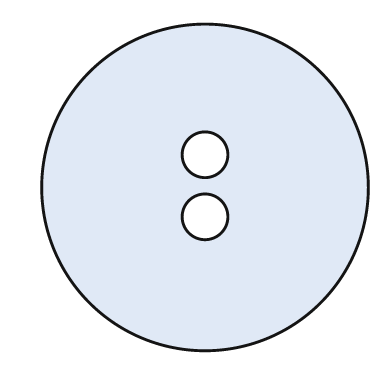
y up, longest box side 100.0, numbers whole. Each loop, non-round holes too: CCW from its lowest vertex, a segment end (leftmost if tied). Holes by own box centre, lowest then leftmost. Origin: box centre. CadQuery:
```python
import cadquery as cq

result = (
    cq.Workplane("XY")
    .moveTo(0.0, 0.0)
    .circle(50.0)
    .moveTo(0.0, -9.0)
    .circle(7.0)
    .moveTo(0.0, 10.0)
    .circle(7.0)
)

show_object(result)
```